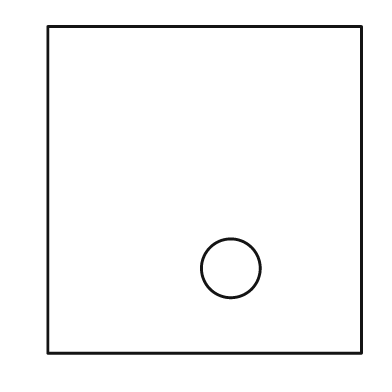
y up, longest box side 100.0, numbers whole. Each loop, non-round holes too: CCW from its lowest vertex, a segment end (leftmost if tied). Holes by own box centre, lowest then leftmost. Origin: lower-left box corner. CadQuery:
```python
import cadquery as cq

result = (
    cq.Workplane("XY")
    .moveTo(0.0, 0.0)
    .lineTo(96.0, 0.0)
    .lineTo(96.0, 100.0)
    .lineTo(0.0, 100.0)
    .close()
    .moveTo(56.0, 26.0)
    .circle(9.0)
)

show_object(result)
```